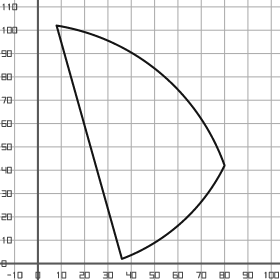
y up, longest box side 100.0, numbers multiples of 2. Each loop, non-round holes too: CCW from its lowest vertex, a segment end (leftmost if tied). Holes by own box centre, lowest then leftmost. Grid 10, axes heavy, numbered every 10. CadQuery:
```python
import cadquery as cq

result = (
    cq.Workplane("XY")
    .moveTo(36.0, 2.0)
    .threePointArc((62.0, 18.0), (80.0, 42.0))
    .threePointArc((52.0, 82.0), (8.0, 102.0))
    .close()
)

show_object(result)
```